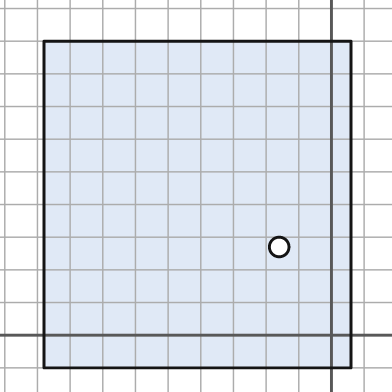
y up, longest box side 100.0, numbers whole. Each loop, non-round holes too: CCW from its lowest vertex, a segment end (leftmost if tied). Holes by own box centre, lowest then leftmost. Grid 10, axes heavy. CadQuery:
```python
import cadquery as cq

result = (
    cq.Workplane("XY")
    .moveTo(-88.0, -10.0)
    .lineTo(6.0, -10.0)
    .lineTo(6.0, 90.0)
    .lineTo(-88.0, 90.0)
    .close()
    .moveTo(-16.0, 27.0)
    .circle(3.0)
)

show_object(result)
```